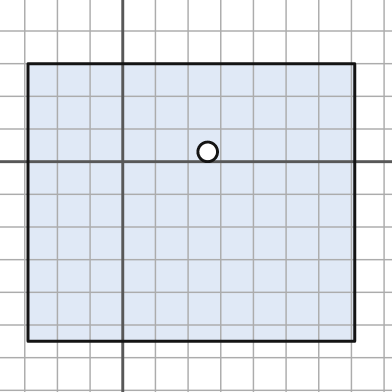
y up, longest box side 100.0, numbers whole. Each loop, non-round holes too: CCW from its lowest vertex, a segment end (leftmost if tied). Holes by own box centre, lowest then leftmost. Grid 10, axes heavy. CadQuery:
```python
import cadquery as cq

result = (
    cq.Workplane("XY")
    .moveTo(-29.0, -55.0)
    .lineTo(71.0, -55.0)
    .lineTo(71.0, 30.0)
    .lineTo(-29.0, 30.0)
    .close()
    .moveTo(26.0, 3.0)
    .circle(3.0)
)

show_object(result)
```